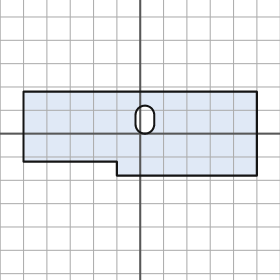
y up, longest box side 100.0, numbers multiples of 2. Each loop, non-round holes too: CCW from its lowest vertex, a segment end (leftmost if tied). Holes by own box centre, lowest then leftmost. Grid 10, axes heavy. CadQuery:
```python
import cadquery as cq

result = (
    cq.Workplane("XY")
    .moveTo(-10.0, -18.0)
    .lineTo(50.0, -18.0)
    .lineTo(50.0, 18.0)
    .lineTo(-50.0, 18.0)
    .lineTo(-50.0, -12.0)
    .lineTo(-10.0, -12.0)
    .close()
    .moveTo(-2.0, 4.0)
    .threePointArc((2.0, 0.0), (6.0, 4.0))
    .lineTo(6.0, 8.0)
    .threePointArc((2.0, 12.0), (-2.0, 8.0))
    .close()
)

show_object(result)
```